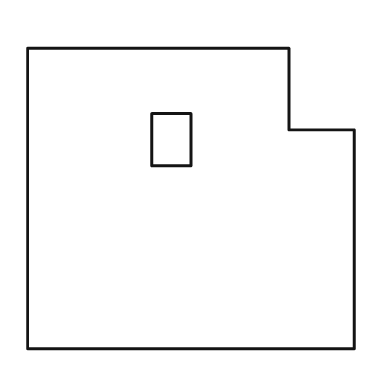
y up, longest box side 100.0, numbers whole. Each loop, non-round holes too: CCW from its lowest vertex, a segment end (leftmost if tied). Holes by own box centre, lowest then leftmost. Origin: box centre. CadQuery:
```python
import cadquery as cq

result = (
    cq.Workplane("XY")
    .moveTo(-50.0, -46.0)
    .lineTo(50.0, -46.0)
    .lineTo(50.0, 21.0)
    .lineTo(30.0, 21.0)
    .lineTo(30.0, 46.0)
    .lineTo(-50.0, 46.0)
    .close()
    .moveTo(-12.0, 10.0)
    .lineTo(0.0, 10.0)
    .lineTo(0.0, 26.0)
    .lineTo(-12.0, 26.0)
    .close()
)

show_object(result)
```